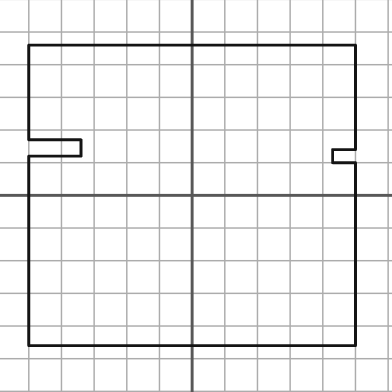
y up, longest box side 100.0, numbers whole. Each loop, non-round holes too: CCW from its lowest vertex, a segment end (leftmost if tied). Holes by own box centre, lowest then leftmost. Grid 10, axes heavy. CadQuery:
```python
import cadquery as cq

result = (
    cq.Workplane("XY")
    .moveTo(-50.0, -46.0)
    .lineTo(50.0, -46.0)
    .lineTo(50.0, 10.0)
    .lineTo(43.0, 10.0)
    .lineTo(43.0, 14.0)
    .lineTo(50.0, 14.0)
    .lineTo(50.0, 46.0)
    .lineTo(-50.0, 46.0)
    .lineTo(-50.0, 17.0)
    .lineTo(-34.0, 17.0)
    .lineTo(-34.0, 12.0)
    .lineTo(-50.0, 12.0)
    .close()
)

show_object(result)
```